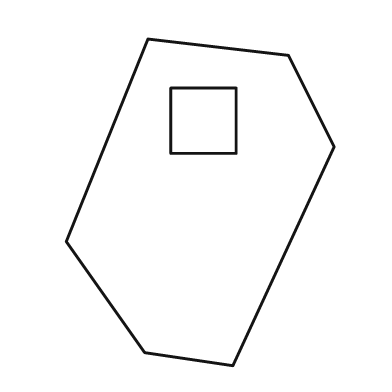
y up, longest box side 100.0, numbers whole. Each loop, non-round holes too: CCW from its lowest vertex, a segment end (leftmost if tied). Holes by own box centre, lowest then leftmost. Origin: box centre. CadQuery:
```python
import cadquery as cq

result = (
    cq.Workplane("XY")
    .moveTo(10.0, -50.0)
    .lineTo(41.0, 17.0)
    .lineTo(27.0, 45.0)
    .lineTo(-16.0, 50.0)
    .lineTo(-41.0, -12.0)
    .lineTo(-17.0, -46.0)
    .close()
    .moveTo(-9.0, 15.0)
    .lineTo(11.0, 15.0)
    .lineTo(11.0, 35.0)
    .lineTo(-9.0, 35.0)
    .close()
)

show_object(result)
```